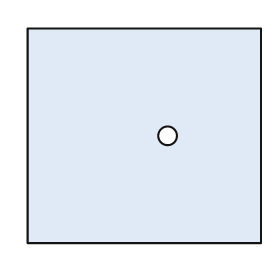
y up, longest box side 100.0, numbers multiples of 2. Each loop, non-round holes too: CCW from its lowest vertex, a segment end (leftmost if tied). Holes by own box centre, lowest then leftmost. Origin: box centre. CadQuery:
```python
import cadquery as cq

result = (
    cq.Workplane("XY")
    .moveTo(-50.0, -46.0)
    .lineTo(50.0, -46.0)
    .lineTo(50.0, 46.0)
    .lineTo(-50.0, 46.0)
    .close()
    .moveTo(10.0, 0.0)
    .circle(4.0)
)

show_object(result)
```